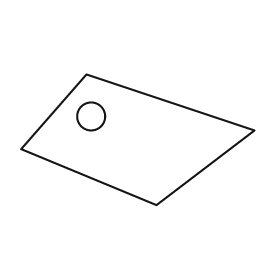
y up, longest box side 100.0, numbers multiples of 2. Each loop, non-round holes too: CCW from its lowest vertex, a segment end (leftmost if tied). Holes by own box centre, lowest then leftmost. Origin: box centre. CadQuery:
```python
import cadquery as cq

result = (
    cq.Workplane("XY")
    .moveTo(8.0, -28.0)
    .lineTo(50.0, 4.0)
    .lineTo(-22.0, 28.0)
    .lineTo(-50.0, -4.0)
    .close()
    .moveTo(-20.0, 10.0)
    .circle(6.0)
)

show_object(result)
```